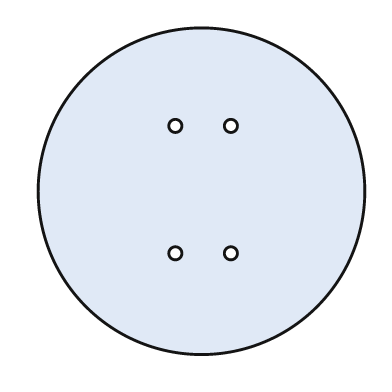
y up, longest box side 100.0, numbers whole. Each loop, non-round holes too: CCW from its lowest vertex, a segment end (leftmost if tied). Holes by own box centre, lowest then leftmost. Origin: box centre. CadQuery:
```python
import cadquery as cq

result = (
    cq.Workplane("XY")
    .moveTo(0.0, 0.0)
    .circle(50.0)
    .moveTo(-8.0, -19.0)
    .circle(2.0)
    .moveTo(9.0, -19.0)
    .circle(2.0)
    .moveTo(-8.0, 20.0)
    .circle(2.0)
    .moveTo(9.0, 20.0)
    .circle(2.0)
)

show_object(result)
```